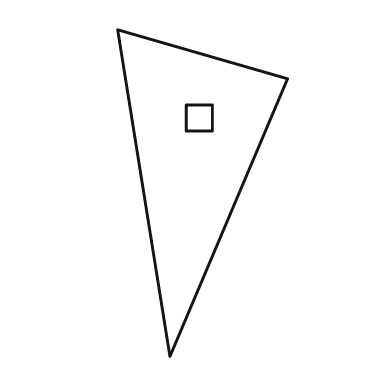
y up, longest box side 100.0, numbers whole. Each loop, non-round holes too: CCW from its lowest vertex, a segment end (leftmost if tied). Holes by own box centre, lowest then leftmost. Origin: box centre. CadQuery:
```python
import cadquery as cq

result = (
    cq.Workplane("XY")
    .moveTo(-10.0, -50.0)
    .lineTo(26.0, 35.0)
    .lineTo(-26.0, 50.0)
    .close()
    .moveTo(-5.0, 19.0)
    .lineTo(3.0, 19.0)
    .lineTo(3.0, 27.0)
    .lineTo(-5.0, 27.0)
    .close()
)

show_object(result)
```